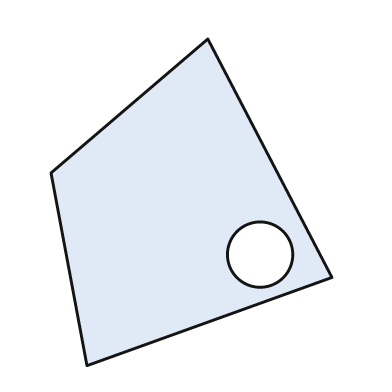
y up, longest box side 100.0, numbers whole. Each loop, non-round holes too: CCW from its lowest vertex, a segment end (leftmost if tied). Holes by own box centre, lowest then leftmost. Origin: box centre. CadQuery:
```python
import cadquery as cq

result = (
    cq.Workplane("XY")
    .moveTo(-32.0, -50.0)
    .lineTo(43.0, -23.0)
    .lineTo(5.0, 50.0)
    .lineTo(-43.0, 9.0)
    .close()
    .moveTo(21.0, -16.0)
    .circle(10.0)
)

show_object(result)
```